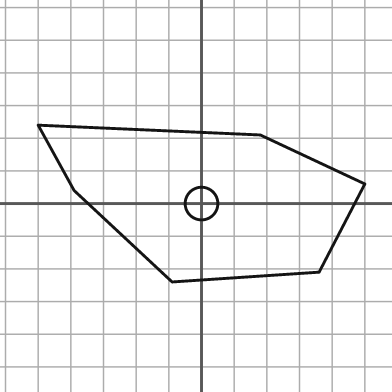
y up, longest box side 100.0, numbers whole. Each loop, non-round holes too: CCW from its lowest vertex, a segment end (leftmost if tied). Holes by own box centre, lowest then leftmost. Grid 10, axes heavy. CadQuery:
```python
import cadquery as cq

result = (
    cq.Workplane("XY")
    .moveTo(-9.0, -24.0)
    .lineTo(36.0, -21.0)
    .lineTo(50.0, 6.0)
    .lineTo(18.0, 21.0)
    .lineTo(-50.0, 24.0)
    .lineTo(-39.0, 4.0)
    .close()
    .moveTo(0.0, 0.0)
    .circle(5.0)
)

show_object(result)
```